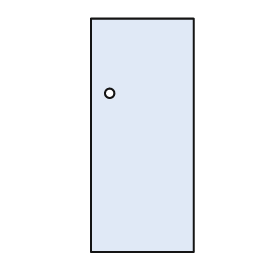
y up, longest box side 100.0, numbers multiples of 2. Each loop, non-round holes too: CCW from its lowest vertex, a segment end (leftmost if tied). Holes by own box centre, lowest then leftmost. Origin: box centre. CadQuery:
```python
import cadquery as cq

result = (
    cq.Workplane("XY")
    .moveTo(-22.0, -50.0)
    .lineTo(22.0, -50.0)
    .lineTo(22.0, 50.0)
    .lineTo(-22.0, 50.0)
    .close()
    .moveTo(-14.0, 18.0)
    .circle(2.0)
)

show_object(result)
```